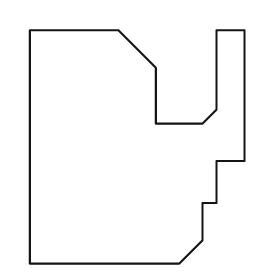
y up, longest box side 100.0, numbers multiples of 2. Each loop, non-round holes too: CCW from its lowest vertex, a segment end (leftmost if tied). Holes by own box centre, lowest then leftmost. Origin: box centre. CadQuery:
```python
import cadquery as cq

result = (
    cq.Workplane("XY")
    .moveTo(-46.0, -50.0)
    .lineTo(18.0, -50.0)
    .lineTo(28.0, -40.0)
    .lineTo(28.0, -24.0)
    .lineTo(34.0, -24.0)
    .lineTo(34.0, -6.0)
    .lineTo(46.0, -6.0)
    .lineTo(46.0, 50.0)
    .lineTo(34.0, 50.0)
    .lineTo(34.0, 16.0)
    .lineTo(28.0, 10.0)
    .lineTo(8.0, 10.0)
    .lineTo(8.0, 34.0)
    .lineTo(-8.0, 50.0)
    .lineTo(-46.0, 50.0)
    .close()
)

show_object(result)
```